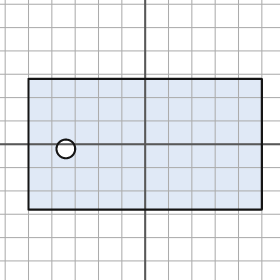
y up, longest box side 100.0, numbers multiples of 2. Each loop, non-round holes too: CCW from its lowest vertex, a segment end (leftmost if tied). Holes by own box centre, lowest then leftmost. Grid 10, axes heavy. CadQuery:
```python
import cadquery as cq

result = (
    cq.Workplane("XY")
    .moveTo(-50.0, -28.0)
    .lineTo(50.0, -28.0)
    .lineTo(50.0, 28.0)
    .lineTo(-50.0, 28.0)
    .close()
    .moveTo(-34.0, -2.0)
    .circle(4.0)
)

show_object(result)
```